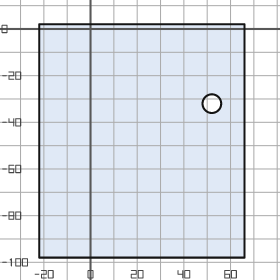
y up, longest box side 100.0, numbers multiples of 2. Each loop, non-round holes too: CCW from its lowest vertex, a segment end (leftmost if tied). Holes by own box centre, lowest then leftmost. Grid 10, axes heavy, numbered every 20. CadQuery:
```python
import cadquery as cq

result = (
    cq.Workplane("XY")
    .moveTo(-22.0, -98.0)
    .lineTo(66.0, -98.0)
    .lineTo(66.0, 2.0)
    .lineTo(-22.0, 2.0)
    .close()
    .moveTo(52.0, -32.0)
    .circle(4.0)
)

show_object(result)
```